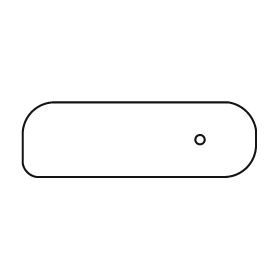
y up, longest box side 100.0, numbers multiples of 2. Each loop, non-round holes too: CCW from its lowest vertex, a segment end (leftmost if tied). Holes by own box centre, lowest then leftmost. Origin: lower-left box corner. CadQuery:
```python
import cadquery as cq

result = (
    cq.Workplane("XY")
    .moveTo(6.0, 0.0)
    .lineTo(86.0, 0.0)
    .threePointArc((96.0, 4.0), (100.0, 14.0))
    .lineTo(100.0, 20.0)
    .threePointArc((96.0, 28.0), (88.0, 32.0))
    .lineTo(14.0, 32.0)
    .threePointArc((4.0, 28.0), (0.0, 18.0))
    .lineTo(0.0, 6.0)
    .threePointArc((2.0, 2.0), (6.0, 0.0))
    .close()
    .moveTo(76.0, 16.0)
    .circle(2.0)
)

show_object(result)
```